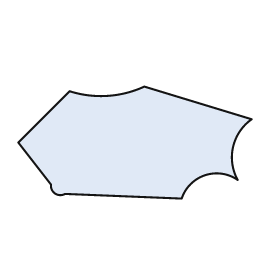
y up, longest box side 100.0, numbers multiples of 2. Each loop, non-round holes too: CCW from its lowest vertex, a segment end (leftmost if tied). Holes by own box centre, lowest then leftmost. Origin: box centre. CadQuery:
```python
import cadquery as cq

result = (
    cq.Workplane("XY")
    .moveTo(20.0, -24.0)
    .threePointArc((30.0, -14.0), (44.0, -16.0))
    .threePointArc((42.0, -2.0), (50.0, 10.0))
    .lineTo(4.0, 24.0)
    .threePointArc((-12.0, 20.0), (-28.0, 22.0))
    .lineTo(-50.0, 0.0)
    .lineTo(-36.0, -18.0)
    .threePointArc((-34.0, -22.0), (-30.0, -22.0))
    .close()
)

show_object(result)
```